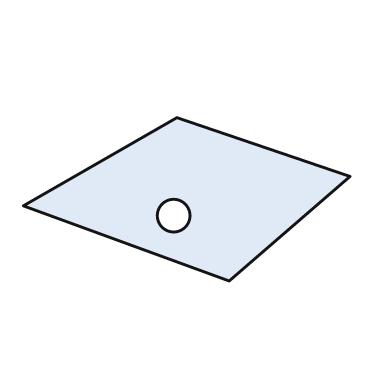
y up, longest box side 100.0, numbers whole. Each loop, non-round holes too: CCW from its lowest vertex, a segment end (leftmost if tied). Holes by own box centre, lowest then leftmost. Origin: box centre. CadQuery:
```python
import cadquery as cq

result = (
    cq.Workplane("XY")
    .moveTo(13.0, -25.0)
    .lineTo(50.0, 7.0)
    .lineTo(-3.0, 25.0)
    .lineTo(-50.0, -2.0)
    .close()
    .moveTo(-4.0, -5.0)
    .circle(5.0)
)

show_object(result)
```